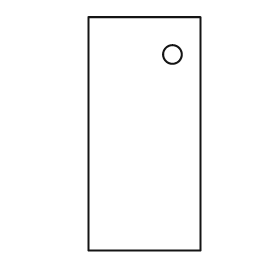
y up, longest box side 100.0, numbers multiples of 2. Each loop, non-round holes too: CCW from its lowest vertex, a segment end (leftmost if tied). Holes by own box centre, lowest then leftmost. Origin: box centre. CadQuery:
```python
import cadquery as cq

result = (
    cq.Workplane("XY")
    .moveTo(-24.0, -50.0)
    .lineTo(24.0, -50.0)
    .lineTo(24.0, 50.0)
    .lineTo(-24.0, 50.0)
    .close()
    .moveTo(12.0, 34.0)
    .circle(4.0)
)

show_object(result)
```